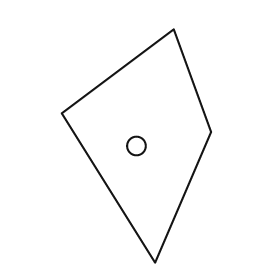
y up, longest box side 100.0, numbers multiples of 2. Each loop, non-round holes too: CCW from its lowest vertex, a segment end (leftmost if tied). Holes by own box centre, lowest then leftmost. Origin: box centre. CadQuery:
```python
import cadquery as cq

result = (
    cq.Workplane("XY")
    .moveTo(8.0, -50.0)
    .lineTo(32.0, 6.0)
    .lineTo(16.0, 50.0)
    .lineTo(-32.0, 14.0)
    .close()
    .moveTo(0.0, 0.0)
    .circle(4.0)
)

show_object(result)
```